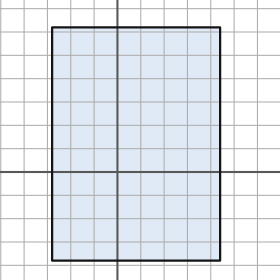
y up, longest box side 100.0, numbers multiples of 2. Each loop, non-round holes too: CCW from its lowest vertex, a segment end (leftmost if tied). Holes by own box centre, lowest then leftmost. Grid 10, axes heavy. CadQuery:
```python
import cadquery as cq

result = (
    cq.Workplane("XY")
    .moveTo(-28.0, -38.0)
    .lineTo(44.0, -38.0)
    .lineTo(44.0, 62.0)
    .lineTo(-28.0, 62.0)
    .close()
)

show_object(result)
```